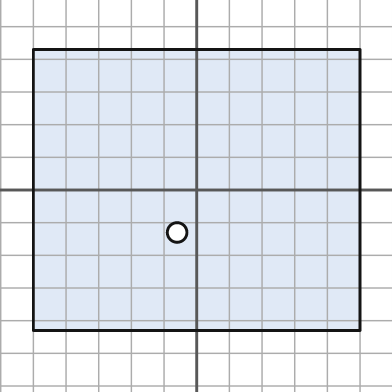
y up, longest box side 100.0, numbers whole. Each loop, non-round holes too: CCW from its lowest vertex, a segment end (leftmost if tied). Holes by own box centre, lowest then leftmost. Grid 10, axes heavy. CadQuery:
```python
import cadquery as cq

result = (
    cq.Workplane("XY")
    .moveTo(-50.0, -43.0)
    .lineTo(50.0, -43.0)
    .lineTo(50.0, 43.0)
    .lineTo(-50.0, 43.0)
    .close()
    .moveTo(-6.0, -13.0)
    .circle(3.0)
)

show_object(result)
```